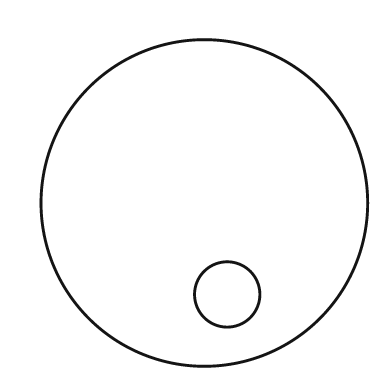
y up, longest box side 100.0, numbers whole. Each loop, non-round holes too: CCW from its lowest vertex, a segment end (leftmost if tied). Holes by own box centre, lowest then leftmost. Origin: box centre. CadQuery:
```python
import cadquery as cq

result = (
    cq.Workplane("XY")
    .moveTo(0.0, 0.0)
    .circle(50.0)
    .moveTo(7.0, -28.0)
    .circle(10.0)
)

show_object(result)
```